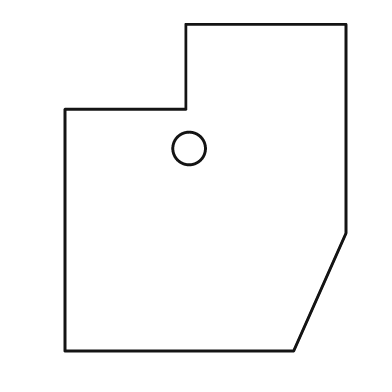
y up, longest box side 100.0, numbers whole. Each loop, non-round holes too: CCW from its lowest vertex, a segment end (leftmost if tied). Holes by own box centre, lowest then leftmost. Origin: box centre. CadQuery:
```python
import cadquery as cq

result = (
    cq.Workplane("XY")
    .moveTo(-43.0, -50.0)
    .lineTo(27.0, -50.0)
    .lineTo(43.0, -14.0)
    .lineTo(43.0, 50.0)
    .lineTo(-6.0, 50.0)
    .lineTo(-6.0, 24.0)
    .lineTo(-43.0, 24.0)
    .close()
    .moveTo(-5.0, 12.0)
    .circle(5.0)
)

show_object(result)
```